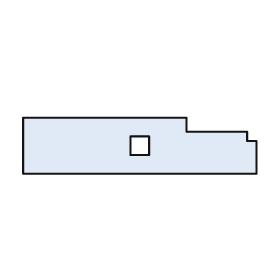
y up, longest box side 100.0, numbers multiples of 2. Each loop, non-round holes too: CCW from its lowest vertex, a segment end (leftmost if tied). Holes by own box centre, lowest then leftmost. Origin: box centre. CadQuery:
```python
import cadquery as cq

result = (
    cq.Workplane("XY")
    .moveTo(-50.0, -12.0)
    .lineTo(50.0, -12.0)
    .lineTo(50.0, 2.0)
    .lineTo(46.0, 2.0)
    .lineTo(46.0, 6.0)
    .lineTo(20.0, 6.0)
    .lineTo(20.0, 12.0)
    .lineTo(-50.0, 12.0)
    .close()
    .moveTo(-4.0, -4.0)
    .lineTo(4.0, -4.0)
    .lineTo(4.0, 4.0)
    .lineTo(-4.0, 4.0)
    .close()
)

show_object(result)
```